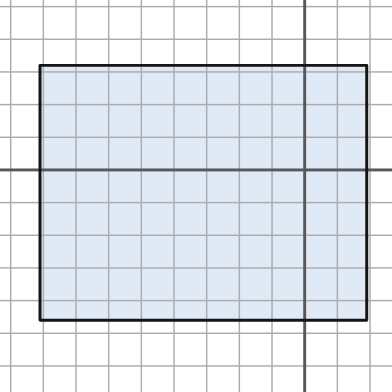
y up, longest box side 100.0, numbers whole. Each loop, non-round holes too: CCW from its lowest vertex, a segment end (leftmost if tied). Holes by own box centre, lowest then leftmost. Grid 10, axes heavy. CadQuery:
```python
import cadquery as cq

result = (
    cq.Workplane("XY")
    .moveTo(-81.0, -46.0)
    .lineTo(19.0, -46.0)
    .lineTo(19.0, 32.0)
    .lineTo(-81.0, 32.0)
    .close()
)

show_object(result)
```